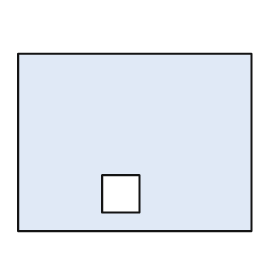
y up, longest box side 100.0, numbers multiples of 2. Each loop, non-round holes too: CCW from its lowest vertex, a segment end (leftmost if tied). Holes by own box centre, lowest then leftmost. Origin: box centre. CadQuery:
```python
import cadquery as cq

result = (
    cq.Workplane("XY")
    .moveTo(-50.0, -38.0)
    .lineTo(50.0, -38.0)
    .lineTo(50.0, 38.0)
    .lineTo(-50.0, 38.0)
    .close()
    .moveTo(-14.0, -30.0)
    .lineTo(2.0, -30.0)
    .lineTo(2.0, -14.0)
    .lineTo(-14.0, -14.0)
    .close()
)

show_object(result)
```